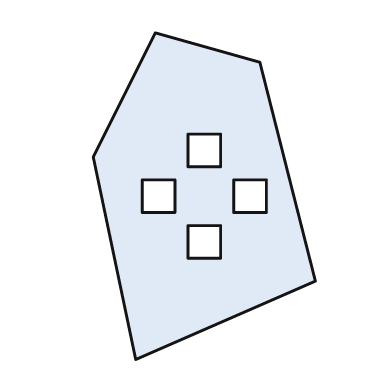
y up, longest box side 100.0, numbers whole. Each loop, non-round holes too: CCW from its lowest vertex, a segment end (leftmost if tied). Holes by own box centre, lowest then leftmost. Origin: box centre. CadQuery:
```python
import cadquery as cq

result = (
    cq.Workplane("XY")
    .moveTo(-21.0, -50.0)
    .lineTo(34.0, -26.0)
    .lineTo(17.0, 41.0)
    .lineTo(-15.0, 50.0)
    .lineTo(-34.0, 12.0)
    .close()
    .moveTo(-5.0, -19.0)
    .lineTo(5.0, -19.0)
    .lineTo(5.0, -9.0)
    .lineTo(-5.0, -9.0)
    .close()
    .moveTo(-19.0, -5.0)
    .lineTo(-9.0, -5.0)
    .lineTo(-9.0, 5.0)
    .lineTo(-19.0, 5.0)
    .close()
    .moveTo(9.0, -5.0)
    .lineTo(19.0, -5.0)
    .lineTo(19.0, 5.0)
    .lineTo(9.0, 5.0)
    .close()
    .moveTo(-5.0, 9.0)
    .lineTo(5.0, 9.0)
    .lineTo(5.0, 19.0)
    .lineTo(-5.0, 19.0)
    .close()
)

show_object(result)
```